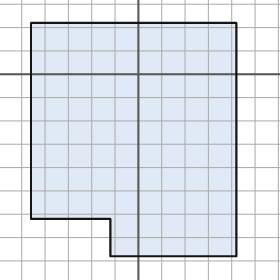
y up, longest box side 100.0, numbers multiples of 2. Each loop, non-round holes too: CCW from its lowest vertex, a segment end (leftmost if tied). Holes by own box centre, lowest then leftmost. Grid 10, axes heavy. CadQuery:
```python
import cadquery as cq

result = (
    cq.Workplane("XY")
    .moveTo(-12.0, -78.0)
    .lineTo(42.0, -78.0)
    .lineTo(42.0, 22.0)
    .lineTo(-46.0, 22.0)
    .lineTo(-46.0, -62.0)
    .lineTo(-12.0, -62.0)
    .close()
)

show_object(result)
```